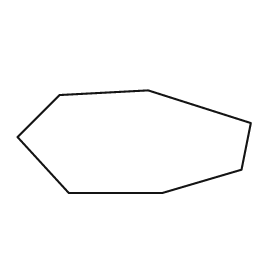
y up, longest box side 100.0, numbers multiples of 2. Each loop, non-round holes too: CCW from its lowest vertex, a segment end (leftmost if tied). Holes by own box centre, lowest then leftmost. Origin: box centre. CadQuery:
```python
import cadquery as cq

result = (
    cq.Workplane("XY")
    .moveTo(-28.0, -22.0)
    .lineTo(12.0, -22.0)
    .lineTo(46.0, -12.0)
    .lineTo(50.0, 8.0)
    .lineTo(6.0, 22.0)
    .lineTo(-32.0, 20.0)
    .lineTo(-50.0, 2.0)
    .close()
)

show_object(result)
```